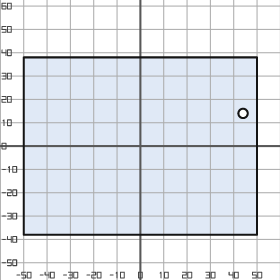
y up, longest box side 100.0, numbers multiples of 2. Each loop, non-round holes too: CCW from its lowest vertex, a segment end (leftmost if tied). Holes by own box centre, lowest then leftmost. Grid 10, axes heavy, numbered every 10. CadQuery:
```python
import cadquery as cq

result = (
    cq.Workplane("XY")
    .moveTo(-50.0, -38.0)
    .lineTo(50.0, -38.0)
    .lineTo(50.0, 38.0)
    .lineTo(-50.0, 38.0)
    .close()
    .moveTo(44.0, 14.0)
    .circle(2.0)
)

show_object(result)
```